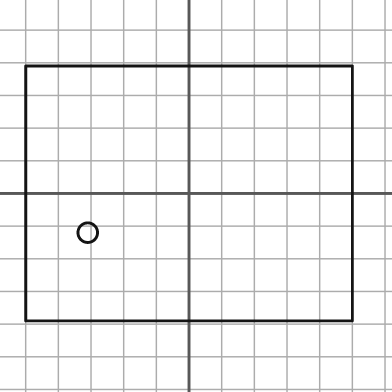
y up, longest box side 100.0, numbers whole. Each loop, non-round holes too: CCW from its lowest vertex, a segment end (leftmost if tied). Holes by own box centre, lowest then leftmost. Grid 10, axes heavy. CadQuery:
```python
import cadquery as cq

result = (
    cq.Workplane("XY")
    .moveTo(-50.0, -39.0)
    .lineTo(50.0, -39.0)
    .lineTo(50.0, 39.0)
    .lineTo(-50.0, 39.0)
    .close()
    .moveTo(-31.0, -12.0)
    .circle(3.0)
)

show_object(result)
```